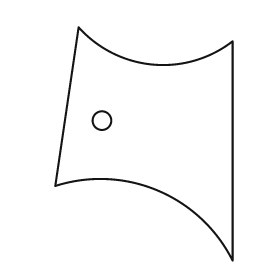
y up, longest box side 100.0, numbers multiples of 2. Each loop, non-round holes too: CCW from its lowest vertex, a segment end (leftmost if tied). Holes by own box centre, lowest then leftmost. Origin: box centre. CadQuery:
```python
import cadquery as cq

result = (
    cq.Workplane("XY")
    .moveTo(38.0, -50.0)
    .lineTo(38.0, 44.0)
    .threePointArc((4.0, 34.0), (-28.0, 50.0))
    .lineTo(-38.0, -18.0)
    .threePointArc((6.0, -20.0), (38.0, -50.0))
    .close()
    .moveTo(-18.0, 10.0)
    .circle(4.0)
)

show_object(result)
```